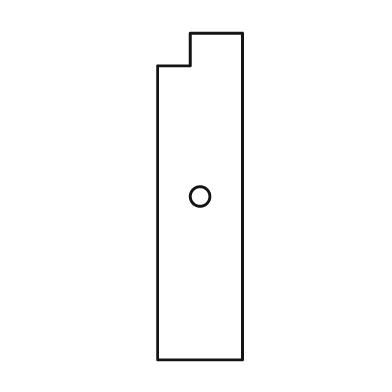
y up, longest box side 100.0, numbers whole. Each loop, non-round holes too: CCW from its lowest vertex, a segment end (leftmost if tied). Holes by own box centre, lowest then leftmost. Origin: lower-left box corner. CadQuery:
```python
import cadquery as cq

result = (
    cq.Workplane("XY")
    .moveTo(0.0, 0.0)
    .lineTo(26.0, 0.0)
    .lineTo(26.0, 100.0)
    .lineTo(10.0, 100.0)
    .lineTo(10.0, 90.0)
    .lineTo(0.0, 90.0)
    .close()
    .moveTo(13.0, 50.0)
    .circle(3.0)
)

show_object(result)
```